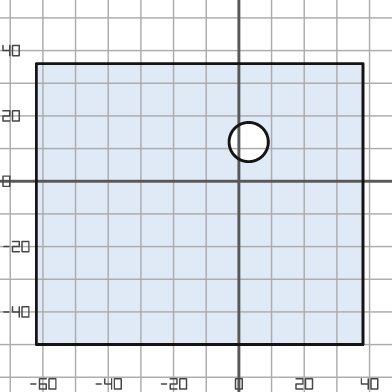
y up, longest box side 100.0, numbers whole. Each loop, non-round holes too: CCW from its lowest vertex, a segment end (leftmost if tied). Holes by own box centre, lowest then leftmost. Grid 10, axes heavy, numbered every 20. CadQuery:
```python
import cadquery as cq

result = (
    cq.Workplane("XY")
    .moveTo(-62.0, -50.0)
    .lineTo(38.0, -50.0)
    .lineTo(38.0, 36.0)
    .lineTo(-62.0, 36.0)
    .close()
    .moveTo(3.0, 12.0)
    .circle(6.0)
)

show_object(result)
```